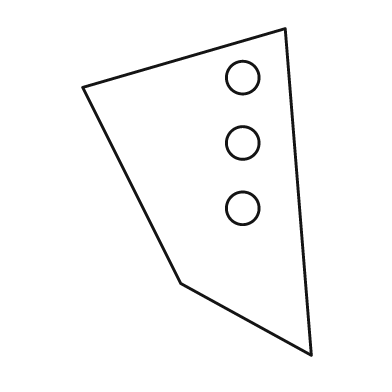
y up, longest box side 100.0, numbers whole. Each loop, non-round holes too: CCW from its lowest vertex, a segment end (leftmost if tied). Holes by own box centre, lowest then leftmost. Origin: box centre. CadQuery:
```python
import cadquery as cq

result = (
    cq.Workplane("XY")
    .moveTo(35.0, -50.0)
    .lineTo(27.0, 50.0)
    .lineTo(-35.0, 32.0)
    .lineTo(-5.0, -28.0)
    .close()
    .moveTo(14.0, -5.0)
    .circle(5.0)
    .moveTo(14.0, 15.0)
    .circle(5.0)
    .moveTo(14.0, 35.0)
    .circle(5.0)
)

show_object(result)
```